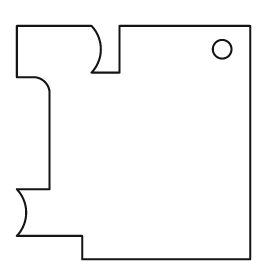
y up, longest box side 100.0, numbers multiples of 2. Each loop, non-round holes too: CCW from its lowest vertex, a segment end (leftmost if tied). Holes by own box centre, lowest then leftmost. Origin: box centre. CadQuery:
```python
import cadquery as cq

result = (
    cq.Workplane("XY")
    .moveTo(-22.0, -50.0)
    .lineTo(50.0, -50.0)
    .lineTo(50.0, 50.0)
    .lineTo(-6.0, 50.0)
    .lineTo(-6.0, 30.0)
    .lineTo(-18.0, 30.0)
    .threePointArc((-14.0, 40.0), (-18.0, 50.0))
    .lineTo(-50.0, 50.0)
    .lineTo(-50.0, 28.0)
    .lineTo(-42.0, 28.0)
    .threePointArc((-38.0, 26.0), (-36.0, 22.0))
    .lineTo(-36.0, -20.0)
    .lineTo(-50.0, -20.0)
    .threePointArc((-46.0, -30.0), (-50.0, -40.0))
    .lineTo(-22.0, -40.0)
    .close()
    .moveTo(38.0, 40.0)
    .circle(4.0)
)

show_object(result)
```